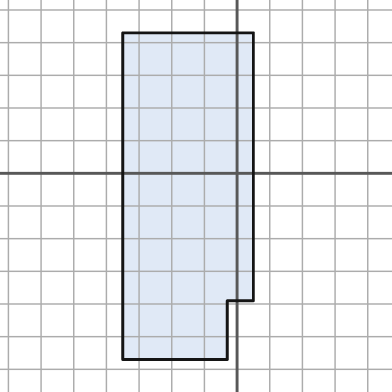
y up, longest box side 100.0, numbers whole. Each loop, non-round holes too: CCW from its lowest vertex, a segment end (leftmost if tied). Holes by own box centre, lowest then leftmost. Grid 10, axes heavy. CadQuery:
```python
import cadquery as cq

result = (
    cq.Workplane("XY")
    .moveTo(-35.0, -57.0)
    .lineTo(-3.0, -57.0)
    .lineTo(-3.0, -39.0)
    .lineTo(5.0, -39.0)
    .lineTo(5.0, 43.0)
    .lineTo(-35.0, 43.0)
    .close()
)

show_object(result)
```